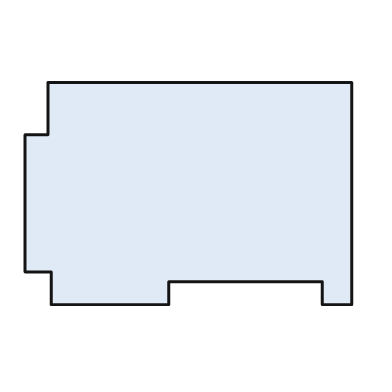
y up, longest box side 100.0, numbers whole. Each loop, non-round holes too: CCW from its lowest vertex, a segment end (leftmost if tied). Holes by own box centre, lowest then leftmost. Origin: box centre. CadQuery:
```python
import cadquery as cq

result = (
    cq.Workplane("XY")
    .moveTo(-42.0, -34.0)
    .lineTo(-6.0, -34.0)
    .lineTo(-6.0, -27.0)
    .lineTo(41.0, -27.0)
    .lineTo(41.0, -34.0)
    .lineTo(50.0, -34.0)
    .lineTo(50.0, 34.0)
    .lineTo(-43.0, 34.0)
    .lineTo(-43.0, 18.0)
    .lineTo(-50.0, 18.0)
    .lineTo(-50.0, -24.0)
    .lineTo(-42.0, -24.0)
    .close()
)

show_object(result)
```